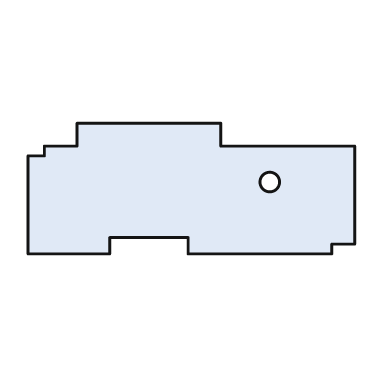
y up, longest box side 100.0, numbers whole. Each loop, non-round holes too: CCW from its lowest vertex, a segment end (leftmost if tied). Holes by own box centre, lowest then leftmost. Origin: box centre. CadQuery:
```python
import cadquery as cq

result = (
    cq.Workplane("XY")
    .moveTo(-50.0, -20.0)
    .lineTo(-25.0, -20.0)
    .lineTo(-25.0, -15.0)
    .lineTo(-1.0, -15.0)
    .lineTo(-1.0, -20.0)
    .lineTo(43.0, -20.0)
    .lineTo(43.0, -17.0)
    .lineTo(50.0, -17.0)
    .lineTo(50.0, 13.0)
    .lineTo(9.0, 13.0)
    .lineTo(9.0, 20.0)
    .lineTo(-35.0, 20.0)
    .lineTo(-35.0, 13.0)
    .lineTo(-45.0, 13.0)
    .lineTo(-45.0, 10.0)
    .lineTo(-50.0, 10.0)
    .close()
    .moveTo(24.0, 2.0)
    .circle(3.0)
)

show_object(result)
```